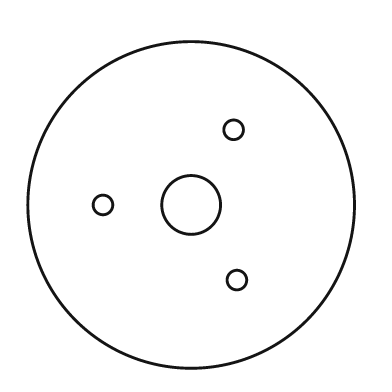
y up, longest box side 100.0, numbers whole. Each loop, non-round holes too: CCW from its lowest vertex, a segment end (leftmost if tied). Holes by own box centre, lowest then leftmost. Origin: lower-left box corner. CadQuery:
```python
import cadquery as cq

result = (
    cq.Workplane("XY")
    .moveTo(50.0, 50.0)
    .circle(50.0)
    .moveTo(64.0, 27.0)
    .circle(3.0)
    .moveTo(23.0, 50.0)
    .circle(3.0)
    .moveTo(50.0, 50.0)
    .circle(9.0)
    .moveTo(63.0, 73.0)
    .circle(3.0)
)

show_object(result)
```